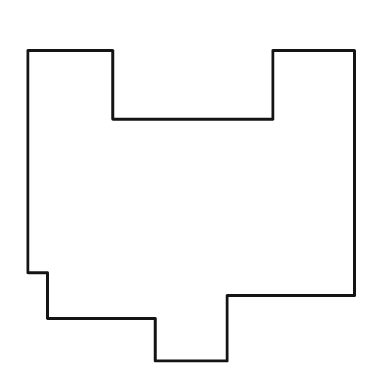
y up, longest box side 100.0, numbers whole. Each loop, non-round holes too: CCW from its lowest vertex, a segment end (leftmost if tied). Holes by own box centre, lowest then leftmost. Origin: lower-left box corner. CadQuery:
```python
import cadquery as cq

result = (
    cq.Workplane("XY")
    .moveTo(39.0, 0.0)
    .lineTo(61.0, 0.0)
    .lineTo(61.0, 20.0)
    .lineTo(100.0, 20.0)
    .lineTo(100.0, 95.0)
    .lineTo(75.0, 95.0)
    .lineTo(75.0, 74.0)
    .lineTo(26.0, 74.0)
    .lineTo(26.0, 95.0)
    .lineTo(0.0, 95.0)
    .lineTo(0.0, 27.0)
    .lineTo(6.0, 27.0)
    .lineTo(6.0, 13.0)
    .lineTo(39.0, 13.0)
    .close()
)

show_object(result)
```